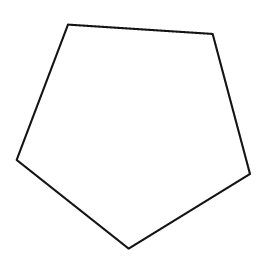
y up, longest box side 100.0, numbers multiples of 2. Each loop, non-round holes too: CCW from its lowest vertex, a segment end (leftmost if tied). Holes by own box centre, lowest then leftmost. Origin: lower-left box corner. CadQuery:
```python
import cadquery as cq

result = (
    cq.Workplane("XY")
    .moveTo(48.0, 0.0)
    .lineTo(100.0, 32.0)
    .lineTo(84.0, 92.0)
    .lineTo(22.0, 96.0)
    .lineTo(0.0, 38.0)
    .close()
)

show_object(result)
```